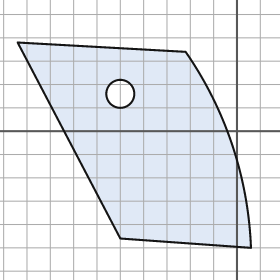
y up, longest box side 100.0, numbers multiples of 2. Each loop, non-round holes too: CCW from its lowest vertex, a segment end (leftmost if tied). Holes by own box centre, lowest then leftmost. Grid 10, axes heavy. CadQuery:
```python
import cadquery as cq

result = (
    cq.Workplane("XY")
    .moveTo(6.0, -50.0)
    .threePointArc((-2.0, -6.0), (-22.0, 34.0))
    .lineTo(-94.0, 38.0)
    .lineTo(-50.0, -46.0)
    .close()
    .moveTo(-50.0, 16.0)
    .circle(6.0)
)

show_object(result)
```